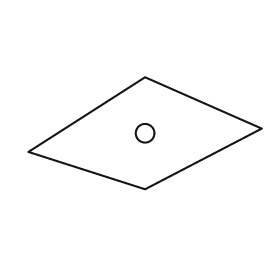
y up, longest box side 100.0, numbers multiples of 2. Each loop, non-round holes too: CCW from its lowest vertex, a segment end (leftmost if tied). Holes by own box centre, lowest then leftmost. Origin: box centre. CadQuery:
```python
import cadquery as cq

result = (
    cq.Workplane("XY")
    .moveTo(0.0, -24.0)
    .lineTo(50.0, 2.0)
    .lineTo(0.0, 24.0)
    .lineTo(-50.0, -8.0)
    .close()
    .moveTo(0.0, 0.0)
    .circle(4.0)
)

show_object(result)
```